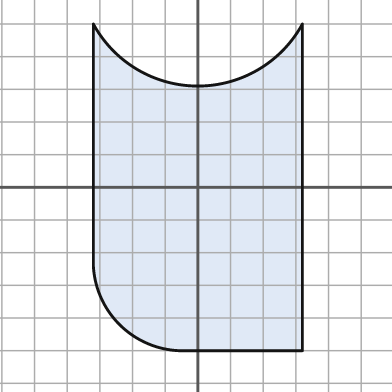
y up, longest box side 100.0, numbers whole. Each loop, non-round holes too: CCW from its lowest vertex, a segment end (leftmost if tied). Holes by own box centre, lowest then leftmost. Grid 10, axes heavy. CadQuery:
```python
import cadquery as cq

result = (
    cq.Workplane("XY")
    .moveTo(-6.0, -50.0)
    .lineTo(32.0, -50.0)
    .lineTo(32.0, 50.0)
    .threePointArc((0.0, 31.0), (-32.0, 50.0))
    .lineTo(-32.0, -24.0)
    .threePointArc((-24.0, -42.0), (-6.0, -50.0))
    .close()
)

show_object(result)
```